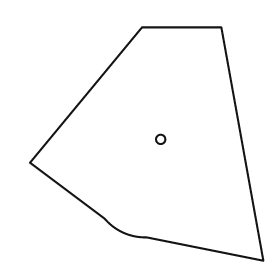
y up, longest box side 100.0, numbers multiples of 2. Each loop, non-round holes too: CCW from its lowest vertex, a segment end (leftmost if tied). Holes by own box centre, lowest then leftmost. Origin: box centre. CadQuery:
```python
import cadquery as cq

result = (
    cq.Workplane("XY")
    .moveTo(50.0, -50.0)
    .lineTo(32.0, 50.0)
    .lineTo(-2.0, 50.0)
    .lineTo(-50.0, -8.0)
    .lineTo(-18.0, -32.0)
    .threePointArc((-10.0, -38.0), (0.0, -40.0))
    .close()
    .moveTo(6.0, 2.0)
    .circle(2.0)
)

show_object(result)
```